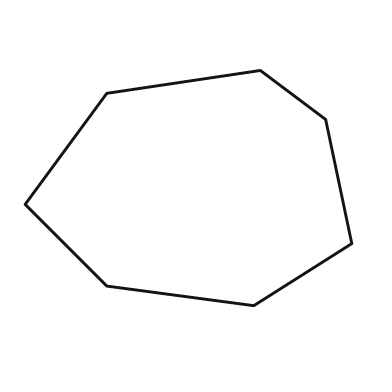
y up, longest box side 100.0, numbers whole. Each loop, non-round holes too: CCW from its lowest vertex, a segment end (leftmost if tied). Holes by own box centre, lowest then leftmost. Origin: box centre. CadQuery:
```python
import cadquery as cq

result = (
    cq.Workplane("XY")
    .moveTo(20.0, -36.0)
    .lineTo(50.0, -17.0)
    .lineTo(42.0, 21.0)
    .lineTo(22.0, 36.0)
    .lineTo(-25.0, 29.0)
    .lineTo(-50.0, -5.0)
    .lineTo(-25.0, -30.0)
    .close()
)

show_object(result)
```